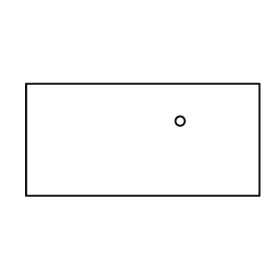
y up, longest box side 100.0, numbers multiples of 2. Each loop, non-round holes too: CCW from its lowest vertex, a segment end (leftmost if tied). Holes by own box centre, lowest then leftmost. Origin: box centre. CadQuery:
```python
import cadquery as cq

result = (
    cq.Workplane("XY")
    .moveTo(-50.0, -24.0)
    .lineTo(50.0, -24.0)
    .lineTo(50.0, 24.0)
    .lineTo(-50.0, 24.0)
    .close()
    .moveTo(16.0, 8.0)
    .circle(2.0)
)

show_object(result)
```